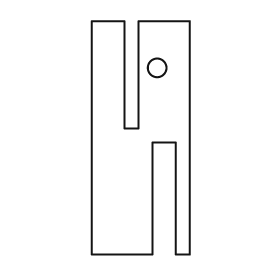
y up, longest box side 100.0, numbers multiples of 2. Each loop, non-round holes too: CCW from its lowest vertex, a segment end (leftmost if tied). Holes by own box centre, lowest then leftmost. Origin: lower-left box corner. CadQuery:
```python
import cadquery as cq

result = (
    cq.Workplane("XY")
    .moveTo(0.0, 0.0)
    .lineTo(26.0, 0.0)
    .lineTo(26.0, 48.0)
    .lineTo(36.0, 48.0)
    .lineTo(36.0, 0.0)
    .lineTo(42.0, 0.0)
    .lineTo(42.0, 100.0)
    .lineTo(20.0, 100.0)
    .lineTo(20.0, 54.0)
    .lineTo(14.0, 54.0)
    .lineTo(14.0, 100.0)
    .lineTo(0.0, 100.0)
    .close()
    .moveTo(28.0, 80.0)
    .circle(4.0)
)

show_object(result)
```